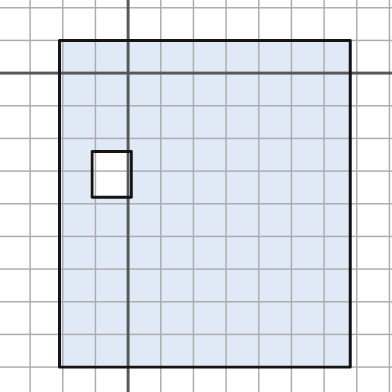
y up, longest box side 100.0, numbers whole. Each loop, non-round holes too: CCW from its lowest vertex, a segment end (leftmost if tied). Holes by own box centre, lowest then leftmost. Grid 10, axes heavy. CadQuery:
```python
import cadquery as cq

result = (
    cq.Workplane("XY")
    .moveTo(-21.0, -90.0)
    .lineTo(68.0, -90.0)
    .lineTo(68.0, 10.0)
    .lineTo(-21.0, 10.0)
    .close()
    .moveTo(-11.0, -38.0)
    .lineTo(1.0, -38.0)
    .lineTo(1.0, -24.0)
    .lineTo(-11.0, -24.0)
    .close()
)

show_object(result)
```